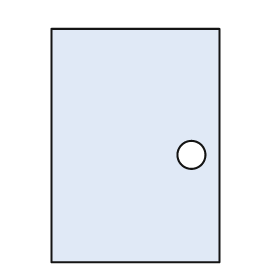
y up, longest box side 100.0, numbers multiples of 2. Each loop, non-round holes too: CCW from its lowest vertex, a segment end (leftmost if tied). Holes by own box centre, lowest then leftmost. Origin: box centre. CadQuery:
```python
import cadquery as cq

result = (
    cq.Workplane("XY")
    .moveTo(-36.0, -50.0)
    .lineTo(36.0, -50.0)
    .lineTo(36.0, 50.0)
    .lineTo(-36.0, 50.0)
    .close()
    .moveTo(24.0, -4.0)
    .circle(6.0)
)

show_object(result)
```